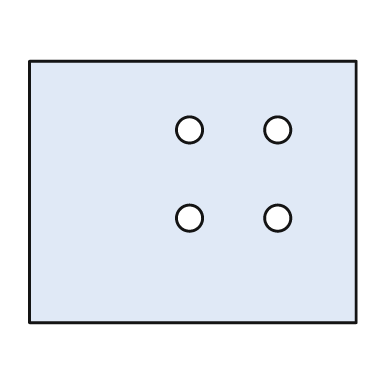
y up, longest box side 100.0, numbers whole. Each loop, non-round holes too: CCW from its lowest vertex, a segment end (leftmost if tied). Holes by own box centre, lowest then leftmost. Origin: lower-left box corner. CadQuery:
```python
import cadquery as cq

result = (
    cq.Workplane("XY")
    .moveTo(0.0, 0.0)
    .lineTo(100.0, 0.0)
    .lineTo(100.0, 80.0)
    .lineTo(0.0, 80.0)
    .close()
    .moveTo(49.0, 32.0)
    .circle(4.0)
    .moveTo(76.0, 32.0)
    .circle(4.0)
    .moveTo(49.0, 59.0)
    .circle(4.0)
    .moveTo(76.0, 59.0)
    .circle(4.0)
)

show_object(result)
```